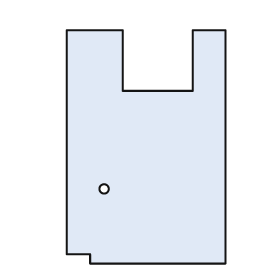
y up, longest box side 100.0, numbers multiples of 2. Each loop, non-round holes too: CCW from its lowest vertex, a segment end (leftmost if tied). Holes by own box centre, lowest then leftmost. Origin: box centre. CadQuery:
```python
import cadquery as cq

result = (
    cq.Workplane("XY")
    .moveTo(-24.0, -50.0)
    .lineTo(34.0, -50.0)
    .lineTo(34.0, 50.0)
    .lineTo(20.0, 50.0)
    .lineTo(20.0, 24.0)
    .lineTo(-10.0, 24.0)
    .lineTo(-10.0, 50.0)
    .lineTo(-34.0, 50.0)
    .lineTo(-34.0, -46.0)
    .lineTo(-24.0, -46.0)
    .close()
    .moveTo(-18.0, -18.0)
    .circle(2.0)
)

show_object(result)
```